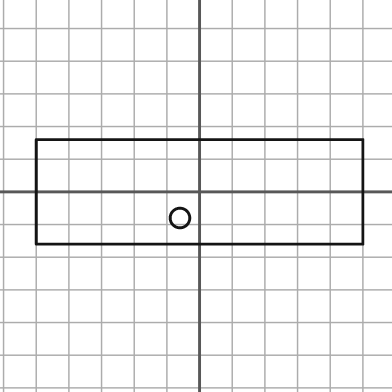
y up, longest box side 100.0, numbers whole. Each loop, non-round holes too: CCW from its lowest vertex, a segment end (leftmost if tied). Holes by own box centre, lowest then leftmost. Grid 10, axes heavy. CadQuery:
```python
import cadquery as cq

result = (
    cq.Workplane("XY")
    .moveTo(-50.0, -16.0)
    .lineTo(50.0, -16.0)
    .lineTo(50.0, 16.0)
    .lineTo(-50.0, 16.0)
    .close()
    .moveTo(-6.0, -8.0)
    .circle(3.0)
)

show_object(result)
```